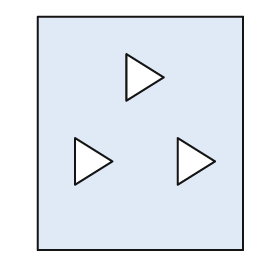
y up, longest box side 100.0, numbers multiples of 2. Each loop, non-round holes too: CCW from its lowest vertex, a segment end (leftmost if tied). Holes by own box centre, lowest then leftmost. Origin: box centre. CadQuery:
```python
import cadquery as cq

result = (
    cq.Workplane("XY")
    .moveTo(-44.0, -50.0)
    .lineTo(44.0, -50.0)
    .lineTo(44.0, 50.0)
    .lineTo(-44.0, 50.0)
    .close()
    .moveTo(-28.0, -22.0)
    .lineTo(-12.0, -12.0)
    .lineTo(-28.0, -2.0)
    .close()
    .moveTo(16.0, -22.0)
    .lineTo(32.0, -12.0)
    .lineTo(16.0, -2.0)
    .close()
    .moveTo(-6.0, 14.0)
    .lineTo(10.0, 24.0)
    .lineTo(-6.0, 34.0)
    .close()
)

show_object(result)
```